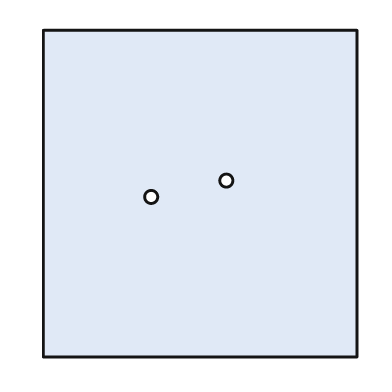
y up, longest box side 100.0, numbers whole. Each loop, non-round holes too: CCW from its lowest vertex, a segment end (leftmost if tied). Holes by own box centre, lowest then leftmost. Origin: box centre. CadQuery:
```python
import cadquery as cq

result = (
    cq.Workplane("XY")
    .moveTo(-48.0, -50.0)
    .lineTo(48.0, -50.0)
    .lineTo(48.0, 50.0)
    .lineTo(-48.0, 50.0)
    .close()
    .moveTo(-15.0, -1.0)
    .circle(2.0)
    .moveTo(8.0, 4.0)
    .circle(2.0)
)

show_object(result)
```